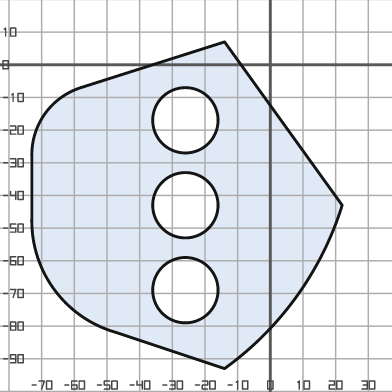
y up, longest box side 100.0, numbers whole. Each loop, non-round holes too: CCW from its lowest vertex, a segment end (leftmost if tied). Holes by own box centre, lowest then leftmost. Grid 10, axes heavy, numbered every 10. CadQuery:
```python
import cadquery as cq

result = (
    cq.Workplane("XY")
    .moveTo(-14.0, -93.0)
    .threePointArc((8.0, -71.0), (22.0, -43.0))
    .lineTo(-14.0, 7.0)
    .lineTo(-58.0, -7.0)
    .threePointArc((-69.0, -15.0), (-73.0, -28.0))
    .lineTo(-73.0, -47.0)
    .threePointArc((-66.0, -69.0), (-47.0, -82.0))
    .close()
    .moveTo(-26.0, -69.0)
    .circle(10.0)
    .moveTo(-26.0, -43.0)
    .circle(10.0)
    .moveTo(-26.0, -17.0)
    .circle(10.0)
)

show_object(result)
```